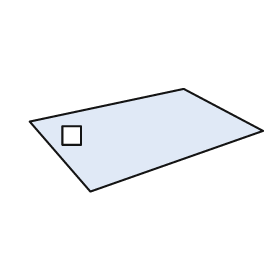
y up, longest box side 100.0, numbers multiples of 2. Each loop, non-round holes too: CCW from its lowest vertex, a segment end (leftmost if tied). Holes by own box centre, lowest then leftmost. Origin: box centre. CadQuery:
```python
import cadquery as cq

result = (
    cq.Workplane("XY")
    .moveTo(-24.0, -22.0)
    .lineTo(50.0, 4.0)
    .lineTo(16.0, 22.0)
    .lineTo(-50.0, 8.0)
    .close()
    .moveTo(-36.0, -2.0)
    .lineTo(-28.0, -2.0)
    .lineTo(-28.0, 6.0)
    .lineTo(-36.0, 6.0)
    .close()
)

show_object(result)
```